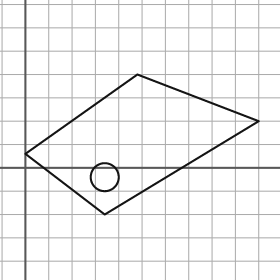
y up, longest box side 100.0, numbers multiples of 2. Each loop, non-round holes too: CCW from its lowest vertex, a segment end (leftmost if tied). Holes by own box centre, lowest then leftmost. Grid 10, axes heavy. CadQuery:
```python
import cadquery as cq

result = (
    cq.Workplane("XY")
    .moveTo(34.0, -20.0)
    .lineTo(100.0, 20.0)
    .lineTo(48.0, 40.0)
    .lineTo(0.0, 6.0)
    .close()
    .moveTo(34.0, -4.0)
    .circle(6.0)
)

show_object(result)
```